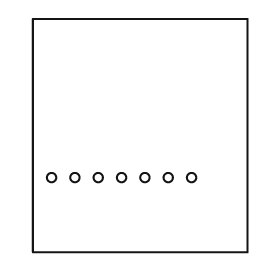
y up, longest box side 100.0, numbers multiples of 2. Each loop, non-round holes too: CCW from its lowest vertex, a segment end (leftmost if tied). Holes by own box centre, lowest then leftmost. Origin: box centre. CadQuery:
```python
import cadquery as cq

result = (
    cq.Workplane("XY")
    .moveTo(-46.0, -50.0)
    .lineTo(46.0, -50.0)
    .lineTo(46.0, 50.0)
    .lineTo(-46.0, 50.0)
    .close()
    .moveTo(-38.0, -18.0)
    .circle(2.0)
    .moveTo(-28.0, -18.0)
    .circle(2.0)
    .moveTo(-18.0, -18.0)
    .circle(2.0)
    .moveTo(-8.0, -18.0)
    .circle(2.0)
    .moveTo(2.0, -18.0)
    .circle(2.0)
    .moveTo(12.0, -18.0)
    .circle(2.0)
    .moveTo(22.0, -18.0)
    .circle(2.0)
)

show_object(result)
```